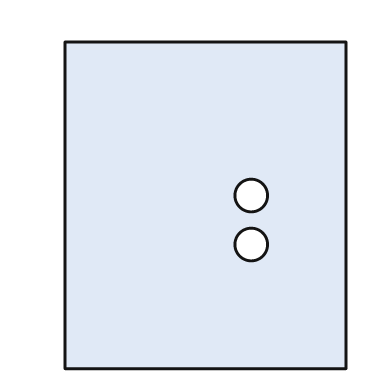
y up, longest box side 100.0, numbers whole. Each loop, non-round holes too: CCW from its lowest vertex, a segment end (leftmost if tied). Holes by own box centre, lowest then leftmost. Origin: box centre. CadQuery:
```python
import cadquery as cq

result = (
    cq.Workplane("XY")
    .moveTo(-43.0, -50.0)
    .lineTo(43.0, -50.0)
    .lineTo(43.0, 50.0)
    .lineTo(-43.0, 50.0)
    .close()
    .moveTo(14.0, -12.0)
    .circle(5.0)
    .moveTo(14.0, 3.0)
    .circle(5.0)
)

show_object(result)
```